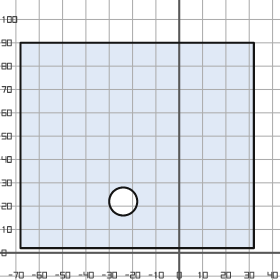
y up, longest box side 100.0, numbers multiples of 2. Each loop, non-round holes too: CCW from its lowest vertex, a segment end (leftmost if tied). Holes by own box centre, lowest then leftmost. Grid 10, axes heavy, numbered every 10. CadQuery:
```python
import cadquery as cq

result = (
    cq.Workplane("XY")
    .moveTo(-68.0, 2.0)
    .lineTo(32.0, 2.0)
    .lineTo(32.0, 90.0)
    .lineTo(-68.0, 90.0)
    .close()
    .moveTo(-24.0, 22.0)
    .circle(6.0)
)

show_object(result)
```